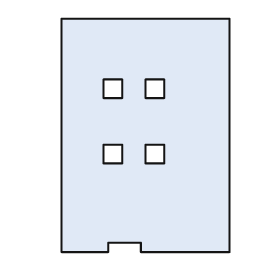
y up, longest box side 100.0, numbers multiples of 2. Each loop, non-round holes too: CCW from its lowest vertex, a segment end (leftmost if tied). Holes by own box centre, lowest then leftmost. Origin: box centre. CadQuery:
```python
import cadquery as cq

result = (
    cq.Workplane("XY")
    .moveTo(-36.0, -50.0)
    .lineTo(-16.0, -50.0)
    .lineTo(-16.0, -46.0)
    .lineTo(-2.0, -46.0)
    .lineTo(-2.0, -50.0)
    .lineTo(36.0, -50.0)
    .lineTo(36.0, 50.0)
    .lineTo(-36.0, 50.0)
    .close()
    .moveTo(-18.0, -12.0)
    .lineTo(-10.0, -12.0)
    .lineTo(-10.0, -4.0)
    .lineTo(-18.0, -4.0)
    .close()
    .moveTo(0.0, -12.0)
    .lineTo(8.0, -12.0)
    .lineTo(8.0, -4.0)
    .lineTo(0.0, -4.0)
    .close()
    .moveTo(-18.0, 16.0)
    .lineTo(-10.0, 16.0)
    .lineTo(-10.0, 24.0)
    .lineTo(-18.0, 24.0)
    .close()
    .moveTo(0.0, 16.0)
    .lineTo(8.0, 16.0)
    .lineTo(8.0, 24.0)
    .lineTo(0.0, 24.0)
    .close()
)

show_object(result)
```